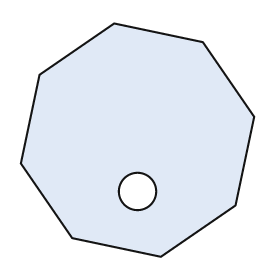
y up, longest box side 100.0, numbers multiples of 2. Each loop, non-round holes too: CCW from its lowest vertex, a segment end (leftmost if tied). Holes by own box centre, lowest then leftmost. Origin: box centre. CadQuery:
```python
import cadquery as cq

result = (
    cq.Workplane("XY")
    .moveTo(10.0, -50.0)
    .lineTo(42.0, -28.0)
    .lineTo(50.0, 10.0)
    .lineTo(28.0, 42.0)
    .lineTo(-10.0, 50.0)
    .lineTo(-42.0, 28.0)
    .lineTo(-50.0, -10.0)
    .lineTo(-28.0, -42.0)
    .close()
    .moveTo(0.0, -22.0)
    .circle(8.0)
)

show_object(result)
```